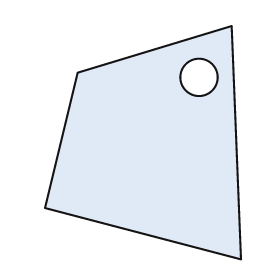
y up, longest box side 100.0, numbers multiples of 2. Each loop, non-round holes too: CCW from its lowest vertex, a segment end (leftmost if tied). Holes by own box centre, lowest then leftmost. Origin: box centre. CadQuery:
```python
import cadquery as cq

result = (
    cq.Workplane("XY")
    .moveTo(42.0, -50.0)
    .lineTo(38.0, 50.0)
    .lineTo(-28.0, 30.0)
    .lineTo(-42.0, -28.0)
    .close()
    .moveTo(24.0, 28.0)
    .circle(8.0)
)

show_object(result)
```